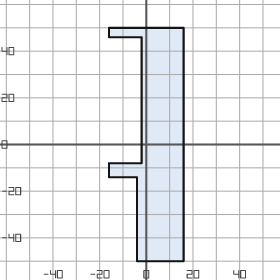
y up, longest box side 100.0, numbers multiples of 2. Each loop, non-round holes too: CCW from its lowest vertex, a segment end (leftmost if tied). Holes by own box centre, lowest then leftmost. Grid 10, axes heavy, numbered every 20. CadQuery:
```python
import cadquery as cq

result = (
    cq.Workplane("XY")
    .moveTo(-4.0, -50.0)
    .lineTo(16.0, -50.0)
    .lineTo(16.0, 50.0)
    .lineTo(-16.0, 50.0)
    .lineTo(-16.0, 46.0)
    .lineTo(-2.0, 46.0)
    .lineTo(-2.0, -8.0)
    .lineTo(-16.0, -8.0)
    .lineTo(-16.0, -14.0)
    .lineTo(-4.0, -14.0)
    .close()
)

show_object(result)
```